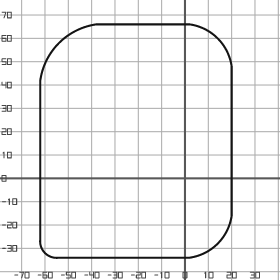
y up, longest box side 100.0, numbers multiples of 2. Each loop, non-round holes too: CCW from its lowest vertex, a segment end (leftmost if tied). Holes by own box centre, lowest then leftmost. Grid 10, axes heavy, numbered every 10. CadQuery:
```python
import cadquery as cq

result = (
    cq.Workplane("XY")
    .moveTo(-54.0, -34.0)
    .lineTo(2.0, -34.0)
    .threePointArc((14.0, -28.0), (20.0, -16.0))
    .lineTo(20.0, 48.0)
    .threePointArc((14.0, 60.0), (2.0, 66.0))
    .lineTo(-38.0, 66.0)
    .threePointArc((-54.0, 58.0), (-62.0, 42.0))
    .lineTo(-62.0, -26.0)
    .threePointArc((-60.0, -32.0), (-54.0, -34.0))
    .close()
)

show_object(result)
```